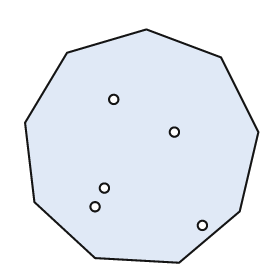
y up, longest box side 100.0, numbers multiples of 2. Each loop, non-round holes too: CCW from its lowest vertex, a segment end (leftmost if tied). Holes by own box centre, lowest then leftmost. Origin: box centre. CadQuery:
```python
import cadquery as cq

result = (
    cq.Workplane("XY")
    .moveTo(16.0, -50.0)
    .lineTo(42.0, -28.0)
    .lineTo(50.0, 6.0)
    .lineTo(34.0, 38.0)
    .lineTo(2.0, 50.0)
    .lineTo(-32.0, 40.0)
    .lineTo(-50.0, 10.0)
    .lineTo(-46.0, -24.0)
    .lineTo(-20.0, -48.0)
    .close()
    .moveTo(26.0, -34.0)
    .circle(2.0)
    .moveTo(-20.0, -26.0)
    .circle(2.0)
    .moveTo(-16.0, -18.0)
    .circle(2.0)
    .moveTo(14.0, 6.0)
    .circle(2.0)
    .moveTo(-12.0, 20.0)
    .circle(2.0)
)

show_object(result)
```